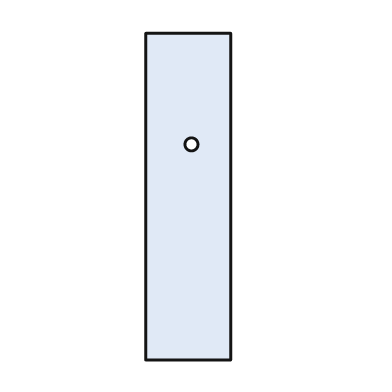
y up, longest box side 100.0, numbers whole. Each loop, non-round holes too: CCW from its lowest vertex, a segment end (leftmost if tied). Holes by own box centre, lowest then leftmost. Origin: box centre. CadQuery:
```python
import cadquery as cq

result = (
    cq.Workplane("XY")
    .moveTo(-13.0, -50.0)
    .lineTo(13.0, -50.0)
    .lineTo(13.0, 50.0)
    .lineTo(-13.0, 50.0)
    .close()
    .moveTo(1.0, 16.0)
    .circle(2.0)
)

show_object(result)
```